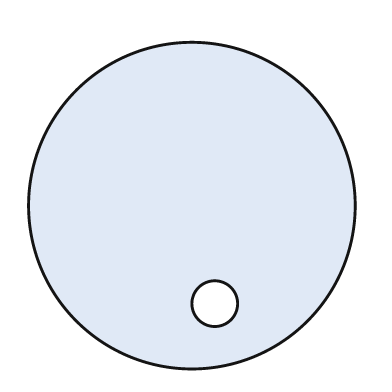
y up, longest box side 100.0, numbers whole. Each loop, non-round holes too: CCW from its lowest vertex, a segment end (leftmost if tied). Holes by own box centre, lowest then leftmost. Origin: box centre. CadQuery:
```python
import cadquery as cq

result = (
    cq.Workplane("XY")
    .moveTo(0.0, 0.0)
    .circle(50.0)
    .moveTo(7.0, -30.0)
    .circle(7.0)
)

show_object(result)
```